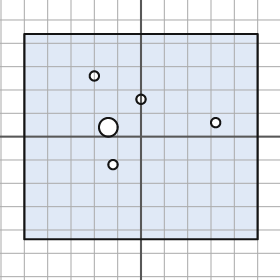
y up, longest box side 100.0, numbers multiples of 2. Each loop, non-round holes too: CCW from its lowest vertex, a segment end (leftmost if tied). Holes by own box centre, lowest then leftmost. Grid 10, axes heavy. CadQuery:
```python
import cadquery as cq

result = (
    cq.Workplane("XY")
    .moveTo(-50.0, -44.0)
    .lineTo(50.0, -44.0)
    .lineTo(50.0, 44.0)
    .lineTo(-50.0, 44.0)
    .close()
    .moveTo(-12.0, -12.0)
    .circle(2.0)
    .moveTo(-14.0, 4.0)
    .circle(4.0)
    .moveTo(32.0, 6.0)
    .circle(2.0)
    .moveTo(0.0, 16.0)
    .circle(2.0)
    .moveTo(-20.0, 26.0)
    .circle(2.0)
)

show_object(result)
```